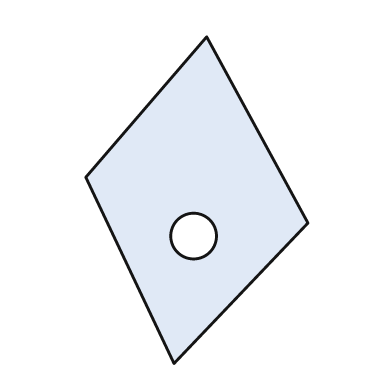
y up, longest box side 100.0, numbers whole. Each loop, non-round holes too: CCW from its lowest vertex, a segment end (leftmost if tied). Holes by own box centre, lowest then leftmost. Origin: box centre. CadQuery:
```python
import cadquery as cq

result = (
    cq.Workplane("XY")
    .moveTo(-7.0, -50.0)
    .lineTo(34.0, -7.0)
    .lineTo(3.0, 50.0)
    .lineTo(-34.0, 7.0)
    .close()
    .moveTo(-1.0, -11.0)
    .circle(7.0)
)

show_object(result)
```